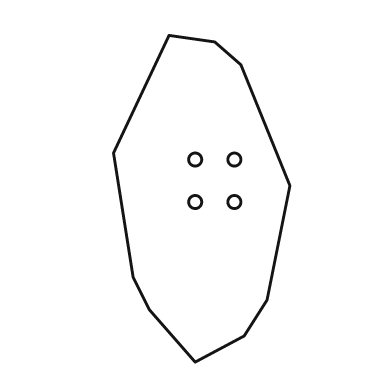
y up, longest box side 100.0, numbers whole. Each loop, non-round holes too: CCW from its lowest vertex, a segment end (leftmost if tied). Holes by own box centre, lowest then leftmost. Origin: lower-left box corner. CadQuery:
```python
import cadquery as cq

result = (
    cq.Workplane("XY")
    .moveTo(25.0, 0.0)
    .lineTo(40.0, 8.0)
    .lineTo(47.0, 19.0)
    .lineTo(54.0, 54.0)
    .lineTo(39.0, 91.0)
    .lineTo(31.0, 98.0)
    .lineTo(17.0, 100.0)
    .lineTo(0.0, 64.0)
    .lineTo(6.0, 26.0)
    .lineTo(11.0, 16.0)
    .close()
    .moveTo(25.0, 49.0)
    .circle(2.0)
    .moveTo(37.0, 49.0)
    .circle(2.0)
    .moveTo(25.0, 62.0)
    .circle(2.0)
    .moveTo(37.0, 62.0)
    .circle(2.0)
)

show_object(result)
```